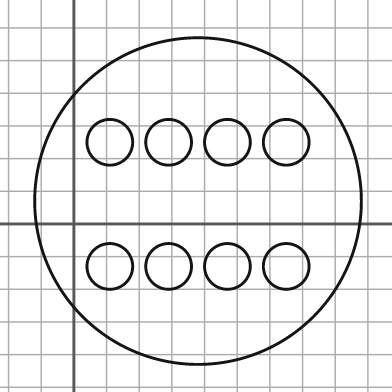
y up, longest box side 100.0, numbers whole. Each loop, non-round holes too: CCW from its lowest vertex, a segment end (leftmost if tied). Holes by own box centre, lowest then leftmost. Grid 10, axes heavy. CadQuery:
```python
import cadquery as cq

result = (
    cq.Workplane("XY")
    .moveTo(38.0, 7.0)
    .circle(50.0)
    .moveTo(11.0, -13.0)
    .circle(7.0)
    .moveTo(29.0, -13.0)
    .circle(7.0)
    .moveTo(47.0, -13.0)
    .circle(7.0)
    .moveTo(65.0, -13.0)
    .circle(7.0)
    .moveTo(11.0, 25.0)
    .circle(7.0)
    .moveTo(29.0, 25.0)
    .circle(7.0)
    .moveTo(47.0, 25.0)
    .circle(7.0)
    .moveTo(65.0, 25.0)
    .circle(7.0)
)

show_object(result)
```